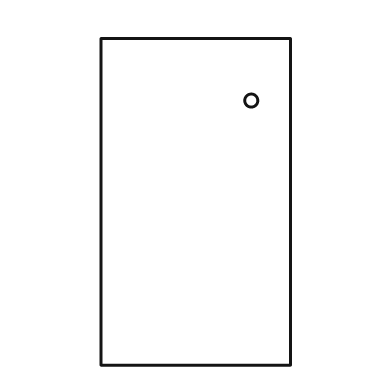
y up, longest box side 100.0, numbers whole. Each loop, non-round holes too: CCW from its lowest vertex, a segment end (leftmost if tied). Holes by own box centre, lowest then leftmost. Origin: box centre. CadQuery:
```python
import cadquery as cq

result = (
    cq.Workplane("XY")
    .moveTo(-29.0, -50.0)
    .lineTo(29.0, -50.0)
    .lineTo(29.0, 50.0)
    .lineTo(-29.0, 50.0)
    .close()
    .moveTo(17.0, 31.0)
    .circle(2.0)
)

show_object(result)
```